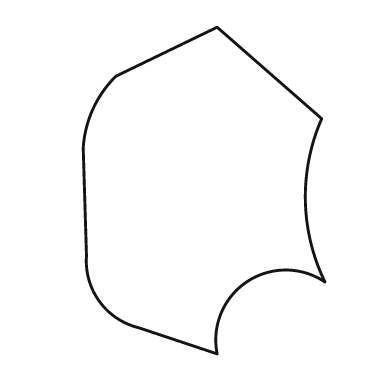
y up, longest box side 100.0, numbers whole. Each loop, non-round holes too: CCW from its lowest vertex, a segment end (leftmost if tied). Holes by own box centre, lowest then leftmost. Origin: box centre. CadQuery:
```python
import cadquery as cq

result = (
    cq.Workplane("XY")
    .moveTo(4.0, -50.0)
    .threePointArc((13.0, -28.0), (37.0, -28.0))
    .threePointArc((31.0, -3.0), (36.0, 22.0))
    .lineTo(4.0, 50.0)
    .lineTo(-27.0, 35.0)
    .threePointArc((-34.0, 25.0), (-37.0, 13.0))
    .lineTo(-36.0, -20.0)
    .threePointArc((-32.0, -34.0), (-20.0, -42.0))
    .close()
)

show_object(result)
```